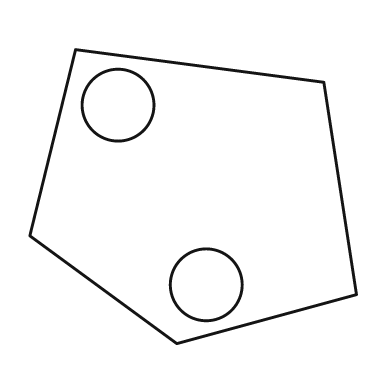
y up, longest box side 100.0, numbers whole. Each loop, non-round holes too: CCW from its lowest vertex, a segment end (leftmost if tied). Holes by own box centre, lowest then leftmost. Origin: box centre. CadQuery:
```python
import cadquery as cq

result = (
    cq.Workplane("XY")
    .moveTo(-5.0, -45.0)
    .lineTo(50.0, -30.0)
    .lineTo(40.0, 35.0)
    .lineTo(-36.0, 45.0)
    .lineTo(-50.0, -12.0)
    .close()
    .moveTo(4.0, -27.0)
    .circle(11.0)
    .moveTo(-23.0, 28.0)
    .circle(11.0)
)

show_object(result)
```